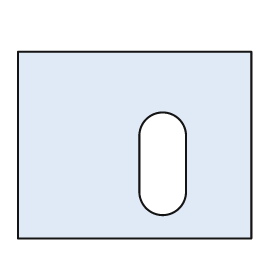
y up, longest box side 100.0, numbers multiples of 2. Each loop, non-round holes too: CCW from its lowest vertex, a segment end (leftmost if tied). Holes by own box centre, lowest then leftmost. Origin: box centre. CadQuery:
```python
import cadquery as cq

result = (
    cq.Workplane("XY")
    .moveTo(-50.0, -40.0)
    .lineTo(50.0, -40.0)
    .lineTo(50.0, 40.0)
    .lineTo(-50.0, 40.0)
    .close()
    .moveTo(2.0, -20.0)
    .threePointArc((12.0, -30.0), (22.0, -20.0))
    .lineTo(22.0, 4.0)
    .threePointArc((12.0, 14.0), (2.0, 4.0))
    .close()
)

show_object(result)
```